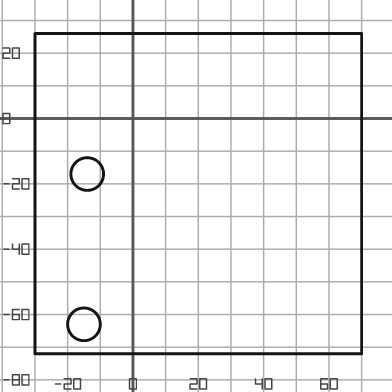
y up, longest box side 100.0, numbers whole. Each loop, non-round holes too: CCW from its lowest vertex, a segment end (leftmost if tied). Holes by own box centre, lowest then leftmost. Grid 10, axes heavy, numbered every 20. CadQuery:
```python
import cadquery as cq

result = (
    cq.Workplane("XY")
    .moveTo(-30.0, -72.0)
    .lineTo(70.0, -72.0)
    .lineTo(70.0, 26.0)
    .lineTo(-30.0, 26.0)
    .close()
    .moveTo(-15.0, -63.0)
    .circle(5.0)
    .moveTo(-14.0, -17.0)
    .circle(5.0)
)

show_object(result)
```